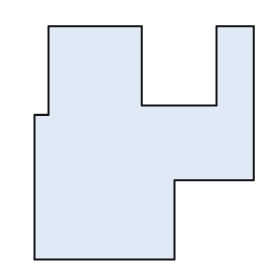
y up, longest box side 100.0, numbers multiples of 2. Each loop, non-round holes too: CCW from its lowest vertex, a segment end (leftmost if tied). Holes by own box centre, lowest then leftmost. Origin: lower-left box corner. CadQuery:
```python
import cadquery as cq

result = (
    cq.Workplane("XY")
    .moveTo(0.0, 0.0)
    .lineTo(60.0, 0.0)
    .lineTo(60.0, 34.0)
    .lineTo(94.0, 34.0)
    .lineTo(94.0, 100.0)
    .lineTo(78.0, 100.0)
    .lineTo(78.0, 66.0)
    .lineTo(46.0, 66.0)
    .lineTo(46.0, 100.0)
    .lineTo(6.0, 100.0)
    .lineTo(6.0, 62.0)
    .lineTo(0.0, 62.0)
    .close()
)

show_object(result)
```